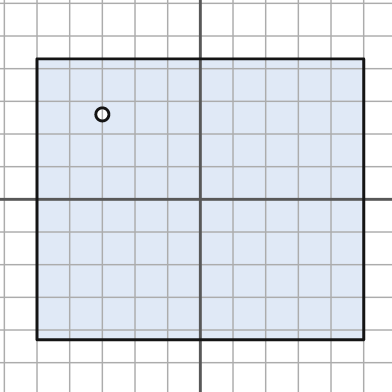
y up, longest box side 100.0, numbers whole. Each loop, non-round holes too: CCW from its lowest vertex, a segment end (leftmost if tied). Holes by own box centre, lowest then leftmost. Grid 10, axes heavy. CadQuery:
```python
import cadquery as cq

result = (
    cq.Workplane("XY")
    .moveTo(-50.0, -43.0)
    .lineTo(50.0, -43.0)
    .lineTo(50.0, 43.0)
    .lineTo(-50.0, 43.0)
    .close()
    .moveTo(-30.0, 26.0)
    .circle(2.0)
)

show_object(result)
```